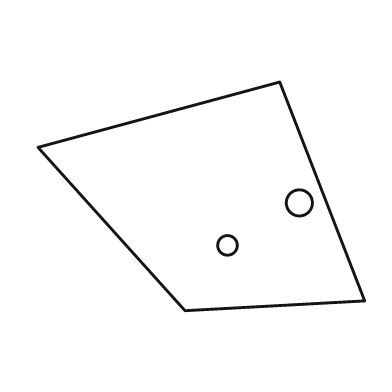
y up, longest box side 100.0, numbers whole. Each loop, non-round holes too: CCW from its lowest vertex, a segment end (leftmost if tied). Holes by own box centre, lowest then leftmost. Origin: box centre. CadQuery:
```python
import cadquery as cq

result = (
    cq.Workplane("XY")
    .moveTo(-5.0, -35.0)
    .lineTo(50.0, -32.0)
    .lineTo(24.0, 35.0)
    .lineTo(-50.0, 15.0)
    .close()
    .moveTo(8.0, -15.0)
    .circle(3.0)
    .moveTo(30.0, -2.0)
    .circle(4.0)
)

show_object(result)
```